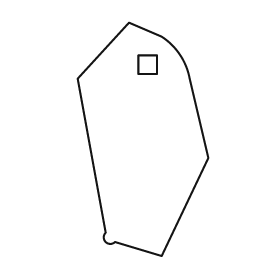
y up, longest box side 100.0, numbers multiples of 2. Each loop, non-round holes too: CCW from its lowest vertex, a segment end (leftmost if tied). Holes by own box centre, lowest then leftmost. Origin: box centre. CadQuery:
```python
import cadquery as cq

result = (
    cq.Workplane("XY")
    .moveTo(8.0, -50.0)
    .lineTo(28.0, -8.0)
    .lineTo(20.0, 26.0)
    .threePointArc((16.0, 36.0), (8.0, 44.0))
    .lineTo(-6.0, 50.0)
    .lineTo(-28.0, 26.0)
    .lineTo(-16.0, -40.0)
    .threePointArc((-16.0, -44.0), (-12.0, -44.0))
    .close()
    .moveTo(-2.0, 28.0)
    .lineTo(6.0, 28.0)
    .lineTo(6.0, 36.0)
    .lineTo(-2.0, 36.0)
    .close()
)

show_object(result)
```